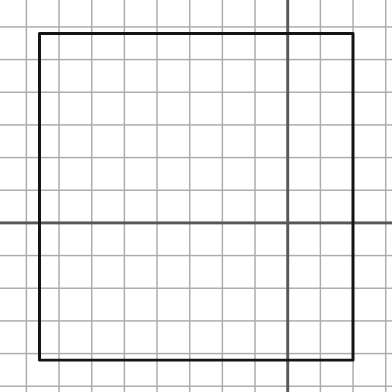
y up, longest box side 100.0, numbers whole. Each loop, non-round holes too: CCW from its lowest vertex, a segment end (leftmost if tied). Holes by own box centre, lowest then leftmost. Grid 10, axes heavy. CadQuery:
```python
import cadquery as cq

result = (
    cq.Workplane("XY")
    .moveTo(-76.0, -42.0)
    .lineTo(20.0, -42.0)
    .lineTo(20.0, 58.0)
    .lineTo(-76.0, 58.0)
    .close()
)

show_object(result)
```